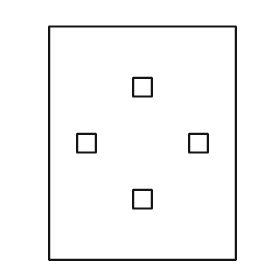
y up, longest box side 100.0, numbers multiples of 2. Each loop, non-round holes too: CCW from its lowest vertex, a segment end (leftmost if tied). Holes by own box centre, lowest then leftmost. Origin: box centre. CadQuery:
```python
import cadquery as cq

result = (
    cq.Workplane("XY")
    .moveTo(-40.0, -50.0)
    .lineTo(40.0, -50.0)
    .lineTo(40.0, 50.0)
    .lineTo(-40.0, 50.0)
    .close()
    .moveTo(-4.0, -28.0)
    .lineTo(4.0, -28.0)
    .lineTo(4.0, -20.0)
    .lineTo(-4.0, -20.0)
    .close()
    .moveTo(-28.0, -4.0)
    .lineTo(-20.0, -4.0)
    .lineTo(-20.0, 4.0)
    .lineTo(-28.0, 4.0)
    .close()
    .moveTo(20.0, -4.0)
    .lineTo(28.0, -4.0)
    .lineTo(28.0, 4.0)
    .lineTo(20.0, 4.0)
    .close()
    .moveTo(-4.0, 20.0)
    .lineTo(4.0, 20.0)
    .lineTo(4.0, 28.0)
    .lineTo(-4.0, 28.0)
    .close()
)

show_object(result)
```